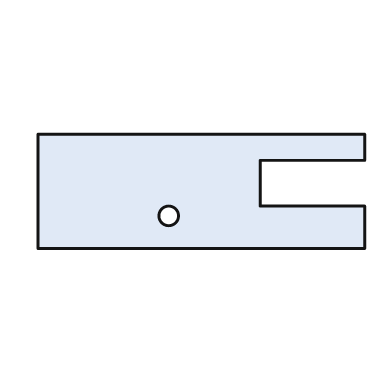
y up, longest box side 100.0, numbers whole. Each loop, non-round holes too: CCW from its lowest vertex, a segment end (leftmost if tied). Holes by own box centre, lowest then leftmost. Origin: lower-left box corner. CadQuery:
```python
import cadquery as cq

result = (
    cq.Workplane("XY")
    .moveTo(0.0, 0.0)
    .lineTo(100.0, 0.0)
    .lineTo(100.0, 13.0)
    .lineTo(68.0, 13.0)
    .lineTo(68.0, 27.0)
    .lineTo(100.0, 27.0)
    .lineTo(100.0, 35.0)
    .lineTo(0.0, 35.0)
    .close()
    .moveTo(40.0, 10.0)
    .circle(3.0)
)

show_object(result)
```